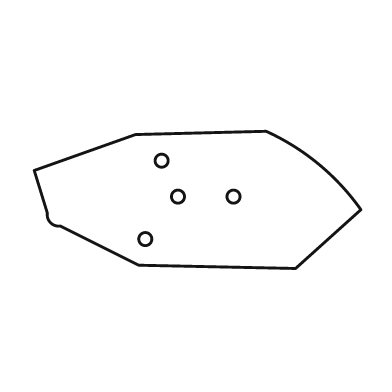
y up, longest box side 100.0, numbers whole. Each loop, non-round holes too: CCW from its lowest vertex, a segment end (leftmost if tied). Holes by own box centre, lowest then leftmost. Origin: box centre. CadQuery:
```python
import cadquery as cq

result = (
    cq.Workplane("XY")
    .moveTo(30.0, -21.0)
    .lineTo(50.0, -3.0)
    .threePointArc((37.0, 11.0), (21.0, 21.0))
    .lineTo(-19.0, 20.0)
    .lineTo(-50.0, 9.0)
    .lineTo(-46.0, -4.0)
    .threePointArc((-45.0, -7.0), (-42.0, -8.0))
    .lineTo(-18.0, -20.0)
    .close()
    .moveTo(-16.0, -12.0)
    .circle(2.0)
    .moveTo(-6.0, 1.0)
    .circle(2.0)
    .moveTo(11.0, 1.0)
    .circle(2.0)
    .moveTo(-11.0, 12.0)
    .circle(2.0)
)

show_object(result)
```